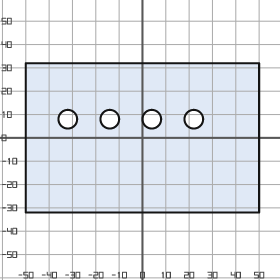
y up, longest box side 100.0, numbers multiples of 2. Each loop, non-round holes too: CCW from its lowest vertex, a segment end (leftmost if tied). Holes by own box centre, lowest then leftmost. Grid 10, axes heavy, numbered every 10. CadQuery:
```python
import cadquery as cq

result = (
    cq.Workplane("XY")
    .moveTo(-50.0, -32.0)
    .lineTo(50.0, -32.0)
    .lineTo(50.0, 32.0)
    .lineTo(-50.0, 32.0)
    .close()
    .moveTo(-32.0, 8.0)
    .circle(4.0)
    .moveTo(-14.0, 8.0)
    .circle(4.0)
    .moveTo(4.0, 8.0)
    .circle(4.0)
    .moveTo(22.0, 8.0)
    .circle(4.0)
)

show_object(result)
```